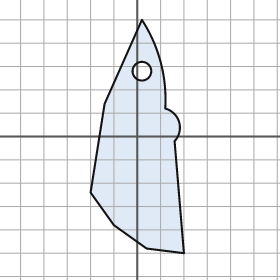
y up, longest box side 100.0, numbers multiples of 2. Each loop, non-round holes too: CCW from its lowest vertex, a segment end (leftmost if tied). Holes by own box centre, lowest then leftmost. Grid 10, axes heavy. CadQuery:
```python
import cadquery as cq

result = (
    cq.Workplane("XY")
    .moveTo(20.0, -50.0)
    .lineTo(16.0, -2.0)
    .threePointArc((18.0, 6.0), (12.0, 12.0))
    .threePointArc((10.0, 32.0), (2.0, 50.0))
    .lineTo(-14.0, 14.0)
    .lineTo(-20.0, -24.0)
    .lineTo(-10.0, -38.0)
    .lineTo(4.0, -48.0)
    .close()
    .moveTo(2.0, 28.0)
    .circle(4.0)
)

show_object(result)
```